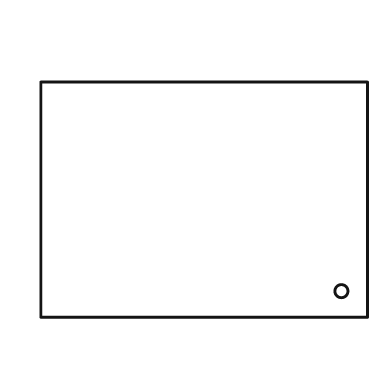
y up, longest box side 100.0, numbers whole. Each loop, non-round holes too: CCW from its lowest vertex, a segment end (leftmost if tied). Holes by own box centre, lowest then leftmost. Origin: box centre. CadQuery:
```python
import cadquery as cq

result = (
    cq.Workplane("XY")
    .moveTo(-50.0, -36.0)
    .lineTo(50.0, -36.0)
    .lineTo(50.0, 36.0)
    .lineTo(-50.0, 36.0)
    .close()
    .moveTo(42.0, -28.0)
    .circle(2.0)
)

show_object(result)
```